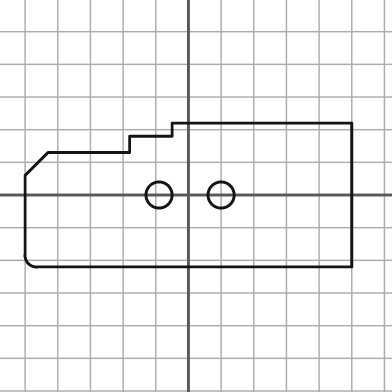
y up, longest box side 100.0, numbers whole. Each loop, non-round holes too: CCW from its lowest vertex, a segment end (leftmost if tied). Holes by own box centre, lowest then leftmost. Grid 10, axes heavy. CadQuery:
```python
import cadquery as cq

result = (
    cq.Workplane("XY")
    .moveTo(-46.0, -22.0)
    .lineTo(50.0, -22.0)
    .lineTo(50.0, 22.0)
    .lineTo(-5.0, 22.0)
    .lineTo(-5.0, 18.0)
    .lineTo(-18.0, 18.0)
    .lineTo(-18.0, 13.0)
    .lineTo(-43.0, 13.0)
    .lineTo(-50.0, 6.0)
    .lineTo(-50.0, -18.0)
    .threePointArc((-49.0, -21.0), (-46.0, -22.0))
    .close()
    .moveTo(-9.0, 0.0)
    .circle(4.0)
    .moveTo(10.0, 0.0)
    .circle(4.0)
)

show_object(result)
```